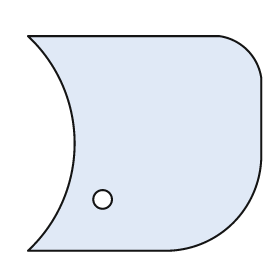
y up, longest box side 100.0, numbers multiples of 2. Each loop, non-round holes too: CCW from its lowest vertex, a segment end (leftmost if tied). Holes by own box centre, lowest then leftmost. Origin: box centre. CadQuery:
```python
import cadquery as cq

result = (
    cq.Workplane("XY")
    .moveTo(-50.0, -46.0)
    .lineTo(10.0, -46.0)
    .threePointArc((38.0, -34.0), (50.0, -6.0))
    .lineTo(50.0, 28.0)
    .threePointArc((44.0, 40.0), (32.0, 46.0))
    .lineTo(-50.0, 46.0)
    .threePointArc((-30.0, 0.0), (-50.0, -46.0))
    .close()
    .moveTo(-18.0, -24.0)
    .circle(4.0)
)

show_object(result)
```